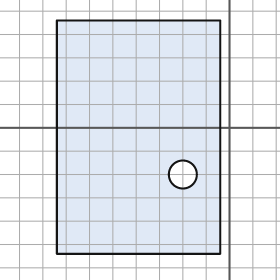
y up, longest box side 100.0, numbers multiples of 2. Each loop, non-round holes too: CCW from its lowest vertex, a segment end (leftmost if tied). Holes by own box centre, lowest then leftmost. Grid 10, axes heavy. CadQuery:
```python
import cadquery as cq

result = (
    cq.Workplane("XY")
    .moveTo(-74.0, -54.0)
    .lineTo(-4.0, -54.0)
    .lineTo(-4.0, 46.0)
    .lineTo(-74.0, 46.0)
    .close()
    .moveTo(-20.0, -20.0)
    .circle(6.0)
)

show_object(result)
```